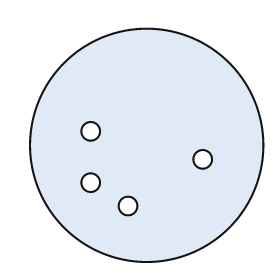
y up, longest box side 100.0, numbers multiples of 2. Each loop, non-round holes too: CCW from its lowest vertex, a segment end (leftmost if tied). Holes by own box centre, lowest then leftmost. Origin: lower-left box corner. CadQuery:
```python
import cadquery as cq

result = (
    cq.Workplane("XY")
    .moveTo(50.0, 50.0)
    .circle(50.0)
    .moveTo(42.0, 24.0)
    .circle(4.0)
    .moveTo(26.0, 34.0)
    .circle(4.0)
    .moveTo(74.0, 44.0)
    .circle(4.0)
    .moveTo(26.0, 56.0)
    .circle(4.0)
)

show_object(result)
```